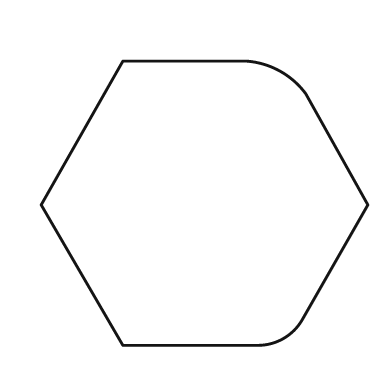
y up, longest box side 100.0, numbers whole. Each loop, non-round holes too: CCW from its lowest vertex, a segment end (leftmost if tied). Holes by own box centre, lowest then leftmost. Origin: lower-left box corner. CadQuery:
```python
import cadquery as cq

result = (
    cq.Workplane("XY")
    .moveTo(25.0, 0.0)
    .lineTo(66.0, 0.0)
    .threePointArc((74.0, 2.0), (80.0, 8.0))
    .lineTo(100.0, 43.0)
    .lineTo(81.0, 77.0)
    .threePointArc((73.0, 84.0), (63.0, 87.0))
    .lineTo(25.0, 87.0)
    .lineTo(0.0, 43.0)
    .close()
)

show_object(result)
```